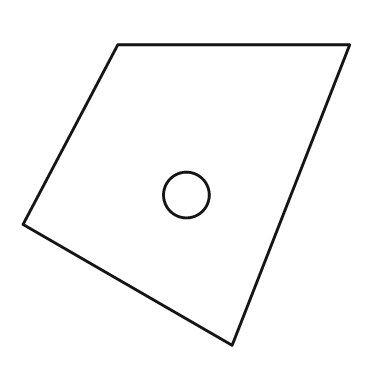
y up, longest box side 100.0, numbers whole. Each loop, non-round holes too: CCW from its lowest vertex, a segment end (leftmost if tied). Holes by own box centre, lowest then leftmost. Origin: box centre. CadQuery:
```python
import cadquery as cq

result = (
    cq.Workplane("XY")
    .moveTo(14.0, -46.0)
    .lineTo(50.0, 46.0)
    .lineTo(-21.0, 46.0)
    .lineTo(-50.0, -9.0)
    .close()
    .moveTo(0.0, 0.0)
    .circle(7.0)
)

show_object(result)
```